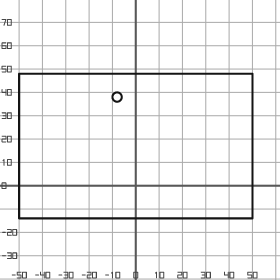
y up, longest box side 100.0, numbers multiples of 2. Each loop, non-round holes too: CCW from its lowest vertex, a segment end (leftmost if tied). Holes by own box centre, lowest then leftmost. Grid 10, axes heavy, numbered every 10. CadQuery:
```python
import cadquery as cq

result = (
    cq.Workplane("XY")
    .moveTo(-50.0, -14.0)
    .lineTo(50.0, -14.0)
    .lineTo(50.0, 48.0)
    .lineTo(-50.0, 48.0)
    .close()
    .moveTo(-8.0, 38.0)
    .circle(2.0)
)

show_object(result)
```